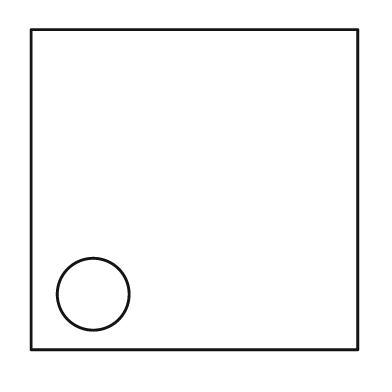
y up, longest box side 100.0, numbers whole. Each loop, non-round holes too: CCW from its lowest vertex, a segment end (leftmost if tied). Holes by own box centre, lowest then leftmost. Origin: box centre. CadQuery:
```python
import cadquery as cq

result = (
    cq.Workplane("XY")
    .moveTo(-50.0, -49.0)
    .lineTo(50.0, -49.0)
    .lineTo(50.0, 49.0)
    .lineTo(-50.0, 49.0)
    .close()
    .moveTo(-31.0, -32.0)
    .circle(11.0)
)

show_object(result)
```